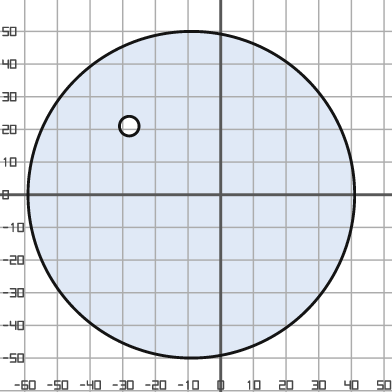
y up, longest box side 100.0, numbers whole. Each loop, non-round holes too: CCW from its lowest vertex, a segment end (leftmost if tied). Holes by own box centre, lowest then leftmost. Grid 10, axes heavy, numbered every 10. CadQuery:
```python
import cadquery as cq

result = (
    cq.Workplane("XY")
    .moveTo(-9.0, 0.0)
    .circle(50.0)
    .moveTo(-28.0, 21.0)
    .circle(3.0)
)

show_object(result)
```